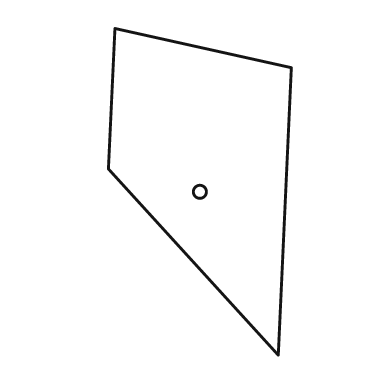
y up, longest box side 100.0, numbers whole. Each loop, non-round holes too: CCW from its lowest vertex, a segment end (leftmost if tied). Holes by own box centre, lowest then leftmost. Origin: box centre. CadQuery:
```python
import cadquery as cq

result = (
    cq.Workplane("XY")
    .moveTo(24.0, -50.0)
    .lineTo(28.0, 38.0)
    .lineTo(-26.0, 50.0)
    .lineTo(-28.0, 7.0)
    .close()
    .moveTo(0.0, 0.0)
    .circle(2.0)
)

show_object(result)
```